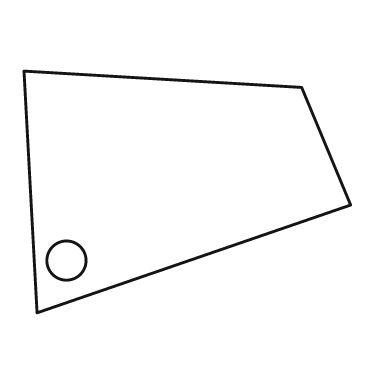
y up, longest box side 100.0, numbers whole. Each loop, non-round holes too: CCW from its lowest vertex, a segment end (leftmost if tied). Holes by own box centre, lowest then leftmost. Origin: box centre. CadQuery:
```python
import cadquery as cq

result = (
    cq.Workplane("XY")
    .moveTo(-46.0, -37.0)
    .lineTo(50.0, -4.0)
    .lineTo(35.0, 32.0)
    .lineTo(-50.0, 37.0)
    .close()
    .moveTo(-37.0, -21.0)
    .circle(6.0)
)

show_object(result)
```